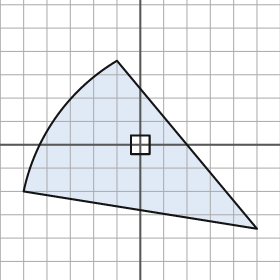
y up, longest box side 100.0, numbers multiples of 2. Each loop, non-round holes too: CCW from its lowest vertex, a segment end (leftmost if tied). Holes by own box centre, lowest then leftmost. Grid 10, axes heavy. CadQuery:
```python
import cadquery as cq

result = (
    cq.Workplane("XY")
    .moveTo(50.0, -36.0)
    .lineTo(-10.0, 36.0)
    .threePointArc((-36.0, 12.0), (-50.0, -20.0))
    .close()
    .moveTo(-4.0, -4.0)
    .lineTo(4.0, -4.0)
    .lineTo(4.0, 4.0)
    .lineTo(-4.0, 4.0)
    .close()
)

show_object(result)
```